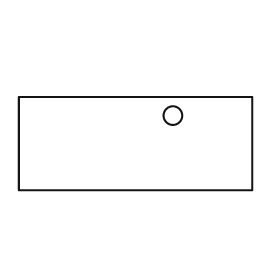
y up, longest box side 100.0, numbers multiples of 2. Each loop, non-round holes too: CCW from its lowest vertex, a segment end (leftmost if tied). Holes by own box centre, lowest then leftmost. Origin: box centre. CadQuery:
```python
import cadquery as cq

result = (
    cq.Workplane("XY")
    .moveTo(-50.0, -20.0)
    .lineTo(50.0, -20.0)
    .lineTo(50.0, 20.0)
    .lineTo(-50.0, 20.0)
    .close()
    .moveTo(16.0, 12.0)
    .circle(4.0)
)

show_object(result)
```